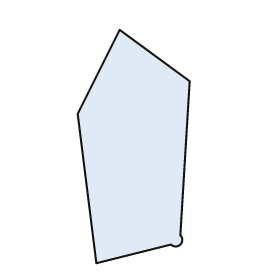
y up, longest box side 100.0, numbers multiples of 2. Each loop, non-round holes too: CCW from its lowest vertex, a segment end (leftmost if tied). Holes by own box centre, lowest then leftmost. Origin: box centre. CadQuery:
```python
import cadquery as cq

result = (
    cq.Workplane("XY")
    .moveTo(-16.0, -50.0)
    .lineTo(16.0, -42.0)
    .threePointArc((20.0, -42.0), (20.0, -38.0))
    .lineTo(24.0, 28.0)
    .lineTo(-6.0, 50.0)
    .lineTo(-24.0, 14.0)
    .close()
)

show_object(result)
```